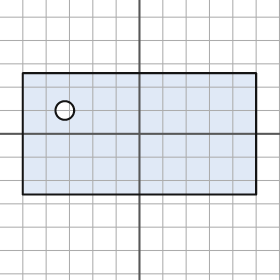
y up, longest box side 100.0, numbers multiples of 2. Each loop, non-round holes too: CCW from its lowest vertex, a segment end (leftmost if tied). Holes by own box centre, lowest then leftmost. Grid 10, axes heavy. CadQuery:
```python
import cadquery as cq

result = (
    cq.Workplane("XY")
    .moveTo(-50.0, -26.0)
    .lineTo(50.0, -26.0)
    .lineTo(50.0, 26.0)
    .lineTo(-50.0, 26.0)
    .close()
    .moveTo(-32.0, 10.0)
    .circle(4.0)
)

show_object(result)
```